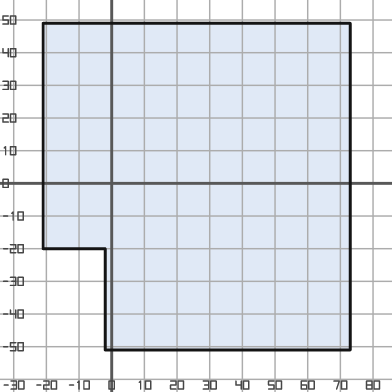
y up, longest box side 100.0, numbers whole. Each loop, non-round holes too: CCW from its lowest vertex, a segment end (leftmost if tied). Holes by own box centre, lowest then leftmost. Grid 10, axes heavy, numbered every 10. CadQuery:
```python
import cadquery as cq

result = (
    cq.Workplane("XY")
    .moveTo(-2.0, -51.0)
    .lineTo(73.0, -51.0)
    .lineTo(73.0, 49.0)
    .lineTo(-21.0, 49.0)
    .lineTo(-21.0, -20.0)
    .lineTo(-2.0, -20.0)
    .close()
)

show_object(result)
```